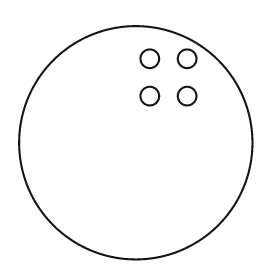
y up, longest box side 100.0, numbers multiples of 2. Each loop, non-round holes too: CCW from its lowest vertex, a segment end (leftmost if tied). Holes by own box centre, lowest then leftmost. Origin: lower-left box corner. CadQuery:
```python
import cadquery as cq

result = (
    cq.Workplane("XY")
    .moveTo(50.0, 50.0)
    .circle(50.0)
    .moveTo(56.0, 70.0)
    .circle(4.0)
    .moveTo(72.0, 70.0)
    .circle(4.0)
    .moveTo(56.0, 86.0)
    .circle(4.0)
    .moveTo(72.0, 86.0)
    .circle(4.0)
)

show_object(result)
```